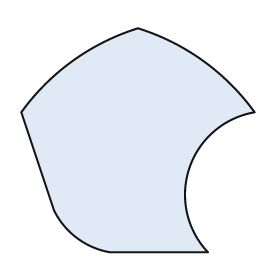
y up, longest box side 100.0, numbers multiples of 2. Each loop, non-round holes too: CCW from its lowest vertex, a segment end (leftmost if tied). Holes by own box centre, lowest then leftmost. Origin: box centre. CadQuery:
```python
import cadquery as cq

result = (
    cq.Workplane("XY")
    .moveTo(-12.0, -48.0)
    .lineTo(30.0, -48.0)
    .threePointArc((22.0, -12.0), (50.0, 12.0))
    .threePointArc((28.0, 34.0), (0.0, 48.0))
    .threePointArc((-28.0, 34.0), (-50.0, 12.0))
    .lineTo(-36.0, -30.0)
    .threePointArc((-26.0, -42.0), (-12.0, -48.0))
    .close()
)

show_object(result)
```